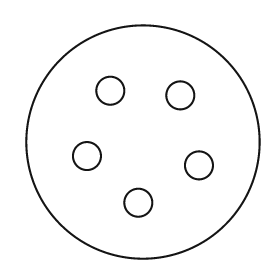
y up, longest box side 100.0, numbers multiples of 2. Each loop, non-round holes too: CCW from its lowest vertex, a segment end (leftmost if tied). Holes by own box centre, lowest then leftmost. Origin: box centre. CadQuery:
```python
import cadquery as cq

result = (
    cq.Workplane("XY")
    .moveTo(0.0, 0.0)
    .circle(50.0)
    .moveTo(-2.0, -26.0)
    .circle(6.0)
    .moveTo(24.0, -10.0)
    .circle(6.0)
    .moveTo(-24.0, -6.0)
    .circle(6.0)
    .moveTo(16.0, 20.0)
    .circle(6.0)
    .moveTo(-14.0, 22.0)
    .circle(6.0)
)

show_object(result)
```